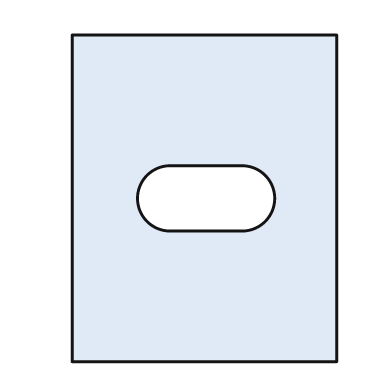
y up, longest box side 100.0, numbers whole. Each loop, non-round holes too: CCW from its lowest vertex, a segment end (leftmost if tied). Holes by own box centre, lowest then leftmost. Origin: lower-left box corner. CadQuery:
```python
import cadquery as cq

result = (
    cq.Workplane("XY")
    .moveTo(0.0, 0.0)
    .lineTo(81.0, 0.0)
    .lineTo(81.0, 100.0)
    .lineTo(0.0, 100.0)
    .close()
    .moveTo(30.0, 40.0)
    .lineTo(52.0, 40.0)
    .threePointArc((62.0, 50.0), (52.0, 60.0))
    .lineTo(30.0, 60.0)
    .threePointArc((20.0, 50.0), (30.0, 40.0))
    .close()
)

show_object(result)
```